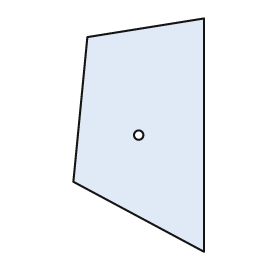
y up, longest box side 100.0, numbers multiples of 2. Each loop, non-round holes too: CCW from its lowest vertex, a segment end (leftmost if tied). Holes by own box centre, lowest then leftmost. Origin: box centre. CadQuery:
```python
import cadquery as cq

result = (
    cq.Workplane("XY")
    .moveTo(28.0, -50.0)
    .lineTo(28.0, 50.0)
    .lineTo(-22.0, 42.0)
    .lineTo(-28.0, -20.0)
    .close()
    .moveTo(0.0, 0.0)
    .circle(2.0)
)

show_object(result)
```